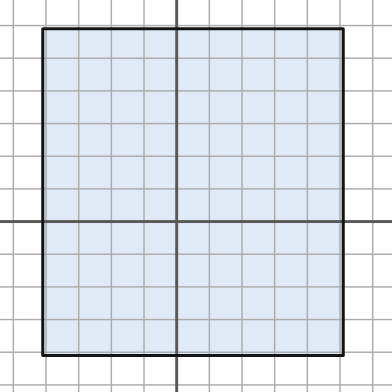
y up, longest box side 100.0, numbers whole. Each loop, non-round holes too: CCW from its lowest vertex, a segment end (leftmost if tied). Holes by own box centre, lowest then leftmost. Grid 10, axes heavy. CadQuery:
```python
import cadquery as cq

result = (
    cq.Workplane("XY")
    .moveTo(-41.0, -41.0)
    .lineTo(51.0, -41.0)
    .lineTo(51.0, 59.0)
    .lineTo(-41.0, 59.0)
    .close()
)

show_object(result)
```